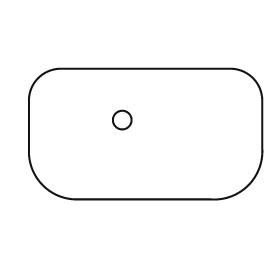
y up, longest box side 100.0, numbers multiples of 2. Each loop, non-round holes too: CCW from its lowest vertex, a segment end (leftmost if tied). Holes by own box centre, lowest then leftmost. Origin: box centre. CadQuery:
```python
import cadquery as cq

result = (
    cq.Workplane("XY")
    .moveTo(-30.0, -28.0)
    .lineTo(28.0, -28.0)
    .threePointArc((44.0, -22.0), (50.0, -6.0))
    .lineTo(50.0, 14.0)
    .threePointArc((46.0, 24.0), (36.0, 28.0))
    .lineTo(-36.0, 28.0)
    .threePointArc((-46.0, 24.0), (-50.0, 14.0))
    .lineTo(-50.0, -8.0)
    .threePointArc((-44.0, -22.0), (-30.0, -28.0))
    .close()
    .moveTo(-10.0, 6.0)
    .circle(4.0)
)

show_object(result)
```